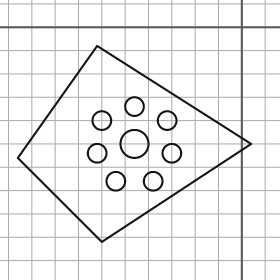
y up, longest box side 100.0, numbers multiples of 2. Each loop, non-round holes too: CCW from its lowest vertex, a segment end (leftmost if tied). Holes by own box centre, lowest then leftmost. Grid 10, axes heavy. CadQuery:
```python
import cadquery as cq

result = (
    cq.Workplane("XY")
    .moveTo(-60.0, -92.0)
    .lineTo(4.0, -50.0)
    .lineTo(-62.0, -8.0)
    .lineTo(-96.0, -56.0)
    .close()
    .moveTo(-54.0, -66.0)
    .circle(4.0)
    .moveTo(-38.0, -66.0)
    .circle(4.0)
    .moveTo(-62.0, -54.0)
    .circle(4.0)
    .moveTo(-30.0, -54.0)
    .circle(4.0)
    .moveTo(-46.0, -50.0)
    .circle(6.0)
    .moveTo(-60.0, -40.0)
    .circle(4.0)
    .moveTo(-32.0, -40.0)
    .circle(4.0)
    .moveTo(-46.0, -34.0)
    .circle(4.0)
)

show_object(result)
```